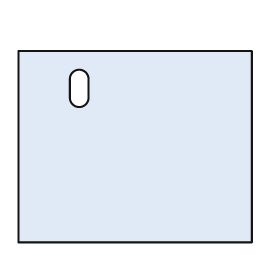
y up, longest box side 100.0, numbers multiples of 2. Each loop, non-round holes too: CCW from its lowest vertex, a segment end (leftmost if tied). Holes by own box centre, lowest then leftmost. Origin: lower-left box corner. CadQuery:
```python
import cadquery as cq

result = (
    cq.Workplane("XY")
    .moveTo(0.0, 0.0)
    .lineTo(100.0, 0.0)
    .lineTo(100.0, 82.0)
    .lineTo(0.0, 82.0)
    .close()
    .moveTo(22.0, 62.0)
    .threePointArc((26.0, 58.0), (30.0, 62.0))
    .lineTo(30.0, 70.0)
    .threePointArc((26.0, 74.0), (22.0, 70.0))
    .close()
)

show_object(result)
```